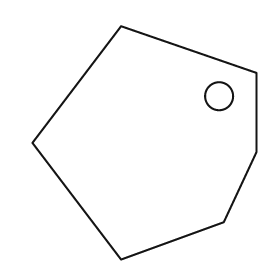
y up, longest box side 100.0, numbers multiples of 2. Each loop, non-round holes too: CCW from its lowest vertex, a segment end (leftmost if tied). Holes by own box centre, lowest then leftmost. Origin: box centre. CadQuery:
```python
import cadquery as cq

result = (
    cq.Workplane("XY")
    .moveTo(-10.0, -50.0)
    .lineTo(34.0, -34.0)
    .lineTo(48.0, -4.0)
    .lineTo(48.0, 30.0)
    .lineTo(-10.0, 50.0)
    .lineTo(-48.0, 0.0)
    .close()
    .moveTo(32.0, 20.0)
    .circle(6.0)
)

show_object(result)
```